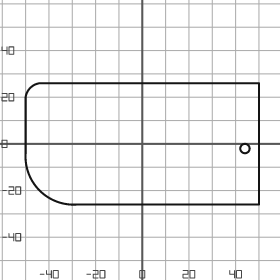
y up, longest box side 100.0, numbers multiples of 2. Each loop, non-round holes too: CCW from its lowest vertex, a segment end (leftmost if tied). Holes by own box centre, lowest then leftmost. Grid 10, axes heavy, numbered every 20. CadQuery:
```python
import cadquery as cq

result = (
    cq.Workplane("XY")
    .moveTo(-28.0, -26.0)
    .lineTo(50.0, -26.0)
    .lineTo(50.0, 26.0)
    .lineTo(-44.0, 26.0)
    .threePointArc((-48.0, 24.0), (-50.0, 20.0))
    .lineTo(-50.0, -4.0)
    .threePointArc((-44.0, -20.0), (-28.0, -26.0))
    .close()
    .moveTo(44.0, -2.0)
    .circle(2.0)
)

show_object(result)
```